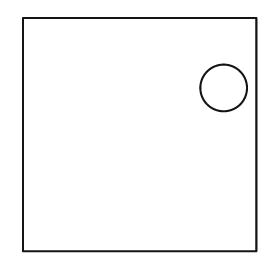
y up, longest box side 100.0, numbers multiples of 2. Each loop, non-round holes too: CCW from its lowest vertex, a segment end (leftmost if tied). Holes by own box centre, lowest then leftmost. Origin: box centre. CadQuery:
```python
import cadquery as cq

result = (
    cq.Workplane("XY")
    .moveTo(-50.0, -50.0)
    .lineTo(50.0, -50.0)
    .lineTo(50.0, 50.0)
    .lineTo(-50.0, 50.0)
    .close()
    .moveTo(36.0, 20.0)
    .circle(10.0)
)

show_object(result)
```